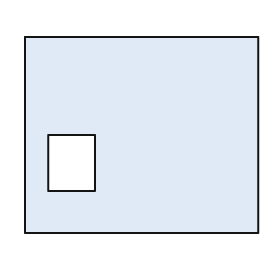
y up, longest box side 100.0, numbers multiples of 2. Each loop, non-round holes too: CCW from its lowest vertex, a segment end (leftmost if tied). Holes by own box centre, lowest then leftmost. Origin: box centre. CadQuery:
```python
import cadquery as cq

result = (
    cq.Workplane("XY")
    .moveTo(-50.0, -42.0)
    .lineTo(50.0, -42.0)
    .lineTo(50.0, 42.0)
    .lineTo(-50.0, 42.0)
    .close()
    .moveTo(-40.0, -24.0)
    .lineTo(-20.0, -24.0)
    .lineTo(-20.0, 0.0)
    .lineTo(-40.0, 0.0)
    .close()
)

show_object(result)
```